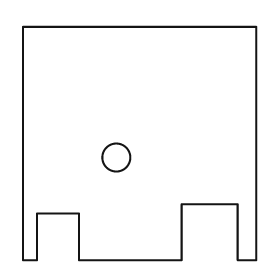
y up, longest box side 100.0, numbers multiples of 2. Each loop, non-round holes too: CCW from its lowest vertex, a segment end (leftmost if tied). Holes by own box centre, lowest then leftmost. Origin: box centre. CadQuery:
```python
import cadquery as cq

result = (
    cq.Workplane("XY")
    .moveTo(-50.0, -50.0)
    .lineTo(-44.0, -50.0)
    .lineTo(-44.0, -30.0)
    .lineTo(-26.0, -30.0)
    .lineTo(-26.0, -50.0)
    .lineTo(18.0, -50.0)
    .lineTo(18.0, -26.0)
    .lineTo(42.0, -26.0)
    .lineTo(42.0, -50.0)
    .lineTo(50.0, -50.0)
    .lineTo(50.0, 50.0)
    .lineTo(-50.0, 50.0)
    .close()
    .moveTo(-10.0, -6.0)
    .circle(6.0)
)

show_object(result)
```